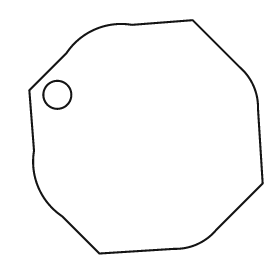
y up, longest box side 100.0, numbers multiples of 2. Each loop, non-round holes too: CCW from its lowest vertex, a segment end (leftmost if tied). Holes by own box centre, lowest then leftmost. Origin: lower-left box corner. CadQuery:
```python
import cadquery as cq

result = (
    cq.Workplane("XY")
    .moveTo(30.0, 0.0)
    .lineTo(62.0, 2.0)
    .threePointArc((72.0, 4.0), (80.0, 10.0))
    .lineTo(100.0, 30.0)
    .lineTo(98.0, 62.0)
    .threePointArc((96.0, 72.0), (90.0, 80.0))
    .lineTo(70.0, 100.0)
    .lineTo(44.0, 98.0)
    .threePointArc((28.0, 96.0), (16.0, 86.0))
    .lineTo(0.0, 70.0)
    .lineTo(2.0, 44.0)
    .threePointArc((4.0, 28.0), (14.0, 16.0))
    .close()
    .moveTo(12.0, 68.0)
    .circle(6.0)
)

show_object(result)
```